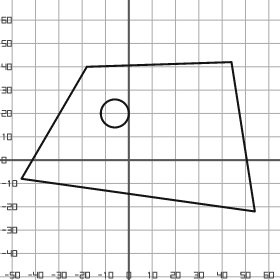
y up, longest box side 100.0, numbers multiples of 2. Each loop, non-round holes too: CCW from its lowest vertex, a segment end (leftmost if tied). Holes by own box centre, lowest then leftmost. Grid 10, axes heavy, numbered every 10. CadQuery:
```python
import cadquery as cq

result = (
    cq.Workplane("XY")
    .moveTo(54.0, -22.0)
    .lineTo(44.0, 42.0)
    .lineTo(-18.0, 40.0)
    .lineTo(-46.0, -8.0)
    .close()
    .moveTo(-6.0, 20.0)
    .circle(6.0)
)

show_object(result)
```